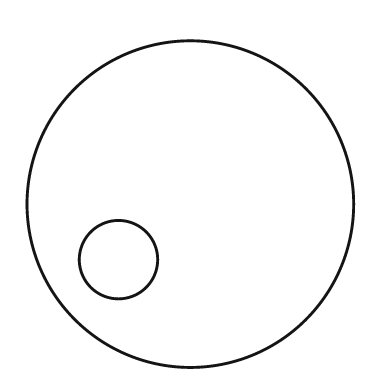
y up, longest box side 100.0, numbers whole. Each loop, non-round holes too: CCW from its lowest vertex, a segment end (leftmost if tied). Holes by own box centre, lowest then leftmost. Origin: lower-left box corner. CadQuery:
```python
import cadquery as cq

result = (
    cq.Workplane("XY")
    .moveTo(50.0, 50.0)
    .circle(50.0)
    .moveTo(28.0, 33.0)
    .circle(12.0)
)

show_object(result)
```